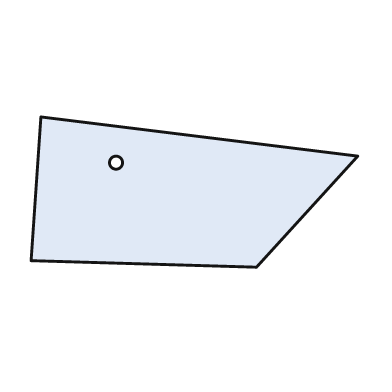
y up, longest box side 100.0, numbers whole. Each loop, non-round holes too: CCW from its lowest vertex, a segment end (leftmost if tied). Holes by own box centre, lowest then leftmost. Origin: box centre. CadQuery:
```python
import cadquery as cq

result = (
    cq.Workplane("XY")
    .moveTo(19.0, -23.0)
    .lineTo(50.0, 11.0)
    .lineTo(-47.0, 23.0)
    .lineTo(-50.0, -21.0)
    .close()
    .moveTo(-24.0, 9.0)
    .circle(2.0)
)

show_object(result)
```